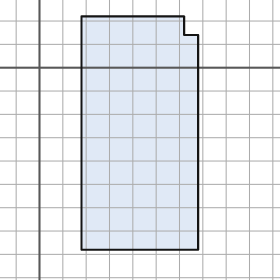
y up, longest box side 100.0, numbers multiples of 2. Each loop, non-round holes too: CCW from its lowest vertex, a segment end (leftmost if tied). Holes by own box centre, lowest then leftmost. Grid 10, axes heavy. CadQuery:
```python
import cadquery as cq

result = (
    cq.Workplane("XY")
    .moveTo(18.0, -78.0)
    .lineTo(68.0, -78.0)
    .lineTo(68.0, 14.0)
    .lineTo(62.0, 14.0)
    .lineTo(62.0, 22.0)
    .lineTo(18.0, 22.0)
    .close()
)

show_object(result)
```